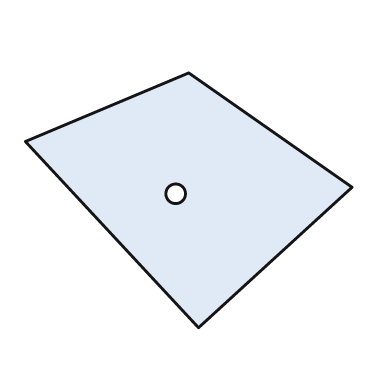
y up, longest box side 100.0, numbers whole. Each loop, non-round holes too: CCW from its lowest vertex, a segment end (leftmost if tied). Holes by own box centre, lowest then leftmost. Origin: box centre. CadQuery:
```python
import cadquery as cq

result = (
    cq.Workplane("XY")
    .moveTo(3.0, -39.0)
    .lineTo(50.0, 4.0)
    .lineTo(0.0, 39.0)
    .lineTo(-50.0, 18.0)
    .close()
    .moveTo(-4.0, 2.0)
    .circle(3.0)
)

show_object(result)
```